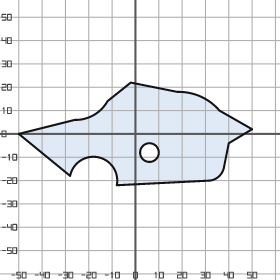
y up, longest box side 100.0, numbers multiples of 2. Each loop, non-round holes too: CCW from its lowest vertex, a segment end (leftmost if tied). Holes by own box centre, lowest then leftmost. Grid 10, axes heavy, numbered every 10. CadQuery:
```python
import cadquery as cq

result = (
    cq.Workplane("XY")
    .moveTo(-8.0, -22.0)
    .lineTo(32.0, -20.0)
    .threePointArc((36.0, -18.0), (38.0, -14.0))
    .lineTo(40.0, -4.0)
    .lineTo(50.0, 2.0)
    .lineTo(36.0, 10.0)
    .threePointArc((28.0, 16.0), (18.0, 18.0))
    .lineTo(-2.0, 22.0)
    .lineTo(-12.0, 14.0)
    .threePointArc((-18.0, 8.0), (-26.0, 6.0))
    .lineTo(-50.0, 0.0)
    .lineTo(-28.0, -18.0)
    .threePointArc((-16.0, -10.0), (-8.0, -22.0))
    .close()
    .moveTo(6.0, -8.0)
    .circle(4.0)
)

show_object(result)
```